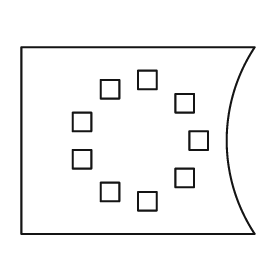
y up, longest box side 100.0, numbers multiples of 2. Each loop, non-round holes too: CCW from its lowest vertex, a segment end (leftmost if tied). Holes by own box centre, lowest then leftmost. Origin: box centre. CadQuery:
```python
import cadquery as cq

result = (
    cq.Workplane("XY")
    .moveTo(-50.0, -40.0)
    .lineTo(50.0, -40.0)
    .threePointArc((38.0, 0.0), (50.0, 40.0))
    .lineTo(-50.0, 40.0)
    .close()
    .moveTo(0.0, -30.0)
    .lineTo(8.0, -30.0)
    .lineTo(8.0, -22.0)
    .lineTo(0.0, -22.0)
    .close()
    .moveTo(-16.0, -26.0)
    .lineTo(-8.0, -26.0)
    .lineTo(-8.0, -18.0)
    .lineTo(-16.0, -18.0)
    .close()
    .moveTo(16.0, -20.0)
    .lineTo(24.0, -20.0)
    .lineTo(24.0, -12.0)
    .lineTo(16.0, -12.0)
    .close()
    .moveTo(-28.0, -12.0)
    .lineTo(-20.0, -12.0)
    .lineTo(-20.0, -4.0)
    .lineTo(-28.0, -4.0)
    .close()
    .moveTo(22.0, -4.0)
    .lineTo(30.0, -4.0)
    .lineTo(30.0, 4.0)
    .lineTo(22.0, 4.0)
    .close()
    .moveTo(-28.0, 4.0)
    .lineTo(-20.0, 4.0)
    .lineTo(-20.0, 12.0)
    .lineTo(-28.0, 12.0)
    .close()
    .moveTo(16.0, 12.0)
    .lineTo(24.0, 12.0)
    .lineTo(24.0, 20.0)
    .lineTo(16.0, 20.0)
    .close()
    .moveTo(-16.0, 18.0)
    .lineTo(-8.0, 18.0)
    .lineTo(-8.0, 26.0)
    .lineTo(-16.0, 26.0)
    .close()
    .moveTo(0.0, 22.0)
    .lineTo(8.0, 22.0)
    .lineTo(8.0, 30.0)
    .lineTo(0.0, 30.0)
    .close()
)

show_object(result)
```